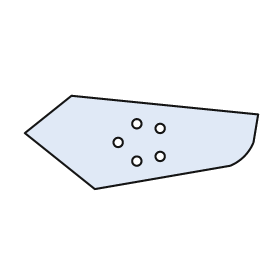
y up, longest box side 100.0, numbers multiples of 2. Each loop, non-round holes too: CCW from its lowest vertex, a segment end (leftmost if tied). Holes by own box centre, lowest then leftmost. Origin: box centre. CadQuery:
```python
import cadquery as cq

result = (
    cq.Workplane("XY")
    .moveTo(-20.0, -20.0)
    .lineTo(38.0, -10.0)
    .threePointArc((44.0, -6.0), (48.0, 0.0))
    .lineTo(50.0, 12.0)
    .lineTo(-30.0, 20.0)
    .lineTo(-50.0, 4.0)
    .close()
    .moveTo(-2.0, -8.0)
    .circle(2.0)
    .moveTo(8.0, -6.0)
    .circle(2.0)
    .moveTo(-10.0, 0.0)
    .circle(2.0)
    .moveTo(8.0, 6.0)
    .circle(2.0)
    .moveTo(-2.0, 8.0)
    .circle(2.0)
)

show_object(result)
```